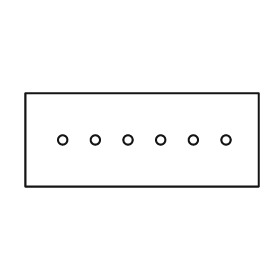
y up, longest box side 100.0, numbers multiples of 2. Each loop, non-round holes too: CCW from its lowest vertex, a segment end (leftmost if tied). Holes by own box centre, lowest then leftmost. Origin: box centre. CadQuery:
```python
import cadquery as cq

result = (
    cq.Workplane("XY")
    .moveTo(-50.0, -20.0)
    .lineTo(50.0, -20.0)
    .lineTo(50.0, 20.0)
    .lineTo(-50.0, 20.0)
    .close()
    .moveTo(-34.0, 0.0)
    .circle(2.0)
    .moveTo(-20.0, 0.0)
    .circle(2.0)
    .moveTo(-6.0, 0.0)
    .circle(2.0)
    .moveTo(8.0, 0.0)
    .circle(2.0)
    .moveTo(22.0, 0.0)
    .circle(2.0)
    .moveTo(36.0, 0.0)
    .circle(2.0)
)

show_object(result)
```